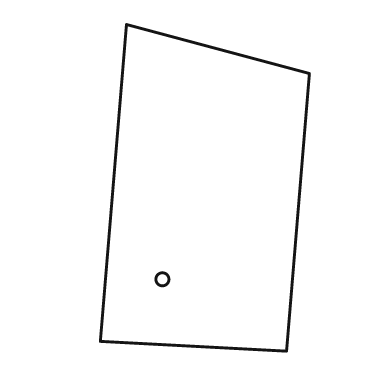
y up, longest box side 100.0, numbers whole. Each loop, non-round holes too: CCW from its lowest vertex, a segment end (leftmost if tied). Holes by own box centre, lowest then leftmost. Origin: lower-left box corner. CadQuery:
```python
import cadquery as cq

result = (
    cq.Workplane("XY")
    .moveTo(57.0, 0.0)
    .lineTo(64.0, 85.0)
    .lineTo(8.0, 100.0)
    .lineTo(0.0, 3.0)
    .close()
    .moveTo(19.0, 22.0)
    .circle(2.0)
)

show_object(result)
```